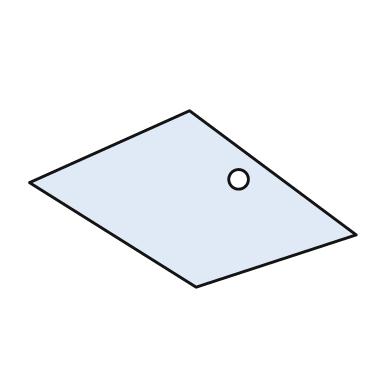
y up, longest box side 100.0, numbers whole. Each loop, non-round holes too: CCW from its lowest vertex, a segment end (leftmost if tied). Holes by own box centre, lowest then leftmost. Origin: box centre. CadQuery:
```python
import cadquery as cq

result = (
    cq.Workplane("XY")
    .moveTo(1.0, -27.0)
    .lineTo(50.0, -11.0)
    .lineTo(-1.0, 27.0)
    .lineTo(-50.0, 5.0)
    .close()
    .moveTo(14.0, 6.0)
    .circle(3.0)
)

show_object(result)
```